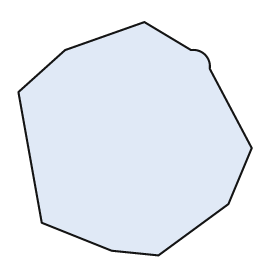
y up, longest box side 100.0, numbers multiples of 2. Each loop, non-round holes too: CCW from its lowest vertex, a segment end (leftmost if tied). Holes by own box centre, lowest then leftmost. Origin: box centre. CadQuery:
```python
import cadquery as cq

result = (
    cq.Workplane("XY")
    .moveTo(10.0, -50.0)
    .lineTo(40.0, -28.0)
    .lineTo(50.0, -4.0)
    .lineTo(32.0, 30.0)
    .threePointArc((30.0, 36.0), (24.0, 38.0))
    .lineTo(4.0, 50.0)
    .lineTo(-30.0, 38.0)
    .lineTo(-50.0, 20.0)
    .lineTo(-40.0, -36.0)
    .lineTo(-10.0, -48.0)
    .close()
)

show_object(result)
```